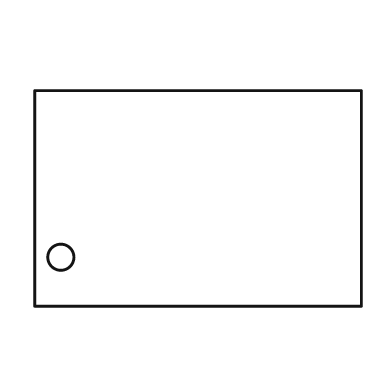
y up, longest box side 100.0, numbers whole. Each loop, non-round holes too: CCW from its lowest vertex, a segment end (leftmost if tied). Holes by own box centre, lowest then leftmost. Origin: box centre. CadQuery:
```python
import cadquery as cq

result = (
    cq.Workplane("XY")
    .moveTo(-50.0, -33.0)
    .lineTo(50.0, -33.0)
    .lineTo(50.0, 33.0)
    .lineTo(-50.0, 33.0)
    .close()
    .moveTo(-42.0, -18.0)
    .circle(4.0)
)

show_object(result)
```